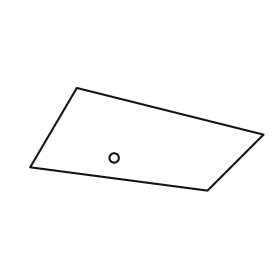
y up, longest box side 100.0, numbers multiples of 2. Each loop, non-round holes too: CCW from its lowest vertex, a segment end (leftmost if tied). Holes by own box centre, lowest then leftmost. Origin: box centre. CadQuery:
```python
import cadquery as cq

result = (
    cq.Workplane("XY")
    .moveTo(26.0, -22.0)
    .lineTo(50.0, 2.0)
    .lineTo(-30.0, 22.0)
    .lineTo(-50.0, -12.0)
    .close()
    .moveTo(-14.0, -8.0)
    .circle(2.0)
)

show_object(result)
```